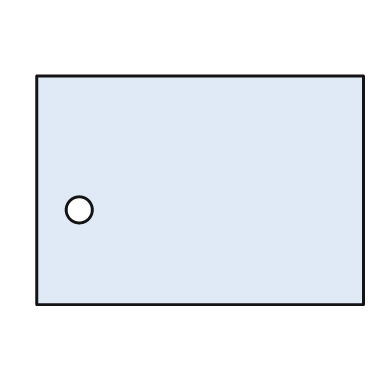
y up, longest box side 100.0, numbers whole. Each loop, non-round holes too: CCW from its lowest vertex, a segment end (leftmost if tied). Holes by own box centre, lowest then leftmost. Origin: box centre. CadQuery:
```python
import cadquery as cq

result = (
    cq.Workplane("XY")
    .moveTo(-50.0, -35.0)
    .lineTo(50.0, -35.0)
    .lineTo(50.0, 35.0)
    .lineTo(-50.0, 35.0)
    .close()
    .moveTo(-37.0, -6.0)
    .circle(4.0)
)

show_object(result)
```